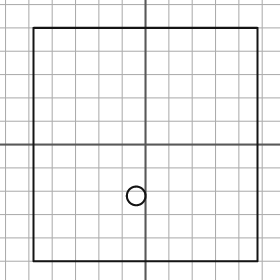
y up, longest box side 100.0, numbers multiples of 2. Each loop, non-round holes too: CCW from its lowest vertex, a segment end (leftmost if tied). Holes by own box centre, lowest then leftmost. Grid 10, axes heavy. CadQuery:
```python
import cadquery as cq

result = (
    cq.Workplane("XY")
    .moveTo(-48.0, -50.0)
    .lineTo(48.0, -50.0)
    .lineTo(48.0, 50.0)
    .lineTo(-48.0, 50.0)
    .close()
    .moveTo(-4.0, -22.0)
    .circle(4.0)
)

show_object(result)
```